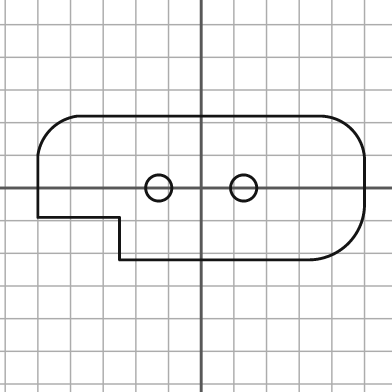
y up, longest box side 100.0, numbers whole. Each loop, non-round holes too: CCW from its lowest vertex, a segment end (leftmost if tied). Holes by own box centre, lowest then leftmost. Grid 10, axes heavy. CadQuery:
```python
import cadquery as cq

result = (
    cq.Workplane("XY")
    .moveTo(-25.0, -22.0)
    .lineTo(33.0, -22.0)
    .threePointArc((45.0, -17.0), (50.0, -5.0))
    .lineTo(50.0, 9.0)
    .threePointArc((46.0, 18.0), (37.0, 22.0))
    .lineTo(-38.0, 22.0)
    .threePointArc((-46.0, 18.0), (-50.0, 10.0))
    .lineTo(-50.0, -9.0)
    .lineTo(-25.0, -9.0)
    .close()
    .moveTo(-13.0, 0.0)
    .circle(4.0)
    .moveTo(13.0, 0.0)
    .circle(4.0)
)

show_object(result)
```